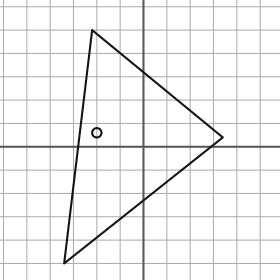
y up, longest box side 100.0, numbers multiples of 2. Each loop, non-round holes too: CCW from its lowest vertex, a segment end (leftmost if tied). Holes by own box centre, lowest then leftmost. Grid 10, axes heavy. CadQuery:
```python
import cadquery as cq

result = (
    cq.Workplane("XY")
    .moveTo(-34.0, -50.0)
    .lineTo(34.0, 4.0)
    .lineTo(-22.0, 50.0)
    .close()
    .moveTo(-20.0, 6.0)
    .circle(2.0)
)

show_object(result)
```